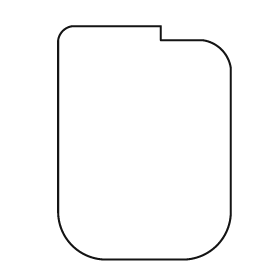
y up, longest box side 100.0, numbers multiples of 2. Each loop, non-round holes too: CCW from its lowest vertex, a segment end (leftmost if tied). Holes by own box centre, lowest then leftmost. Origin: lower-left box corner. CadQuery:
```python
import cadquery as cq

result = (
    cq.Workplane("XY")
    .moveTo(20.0, 0.0)
    .lineTo(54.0, 0.0)
    .threePointArc((68.0, 6.0), (74.0, 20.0))
    .lineTo(74.0, 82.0)
    .threePointArc((70.0, 90.0), (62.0, 94.0))
    .lineTo(44.0, 94.0)
    .lineTo(44.0, 100.0)
    .lineTo(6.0, 100.0)
    .threePointArc((2.0, 98.0), (0.0, 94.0))
    .lineTo(0.0, 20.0)
    .threePointArc((6.0, 6.0), (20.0, 0.0))
    .close()
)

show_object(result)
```